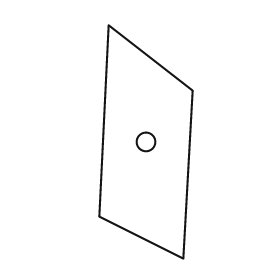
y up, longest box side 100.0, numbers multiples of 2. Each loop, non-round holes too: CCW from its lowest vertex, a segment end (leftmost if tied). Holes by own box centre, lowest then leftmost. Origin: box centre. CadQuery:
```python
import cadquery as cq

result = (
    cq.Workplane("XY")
    .moveTo(16.0, -50.0)
    .lineTo(20.0, 22.0)
    .lineTo(-16.0, 50.0)
    .lineTo(-20.0, -32.0)
    .close()
    .moveTo(0.0, 0.0)
    .circle(4.0)
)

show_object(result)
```